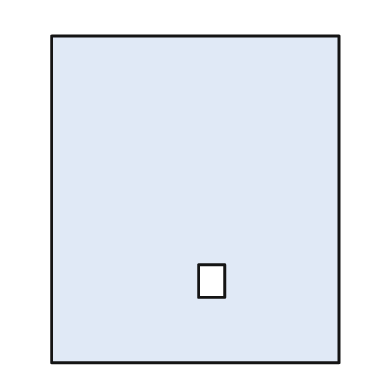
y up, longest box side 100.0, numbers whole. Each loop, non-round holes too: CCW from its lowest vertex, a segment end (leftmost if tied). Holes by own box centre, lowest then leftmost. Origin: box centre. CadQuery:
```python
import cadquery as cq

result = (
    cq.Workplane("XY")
    .moveTo(-44.0, -50.0)
    .lineTo(44.0, -50.0)
    .lineTo(44.0, 50.0)
    .lineTo(-44.0, 50.0)
    .close()
    .moveTo(1.0, -30.0)
    .lineTo(9.0, -30.0)
    .lineTo(9.0, -20.0)
    .lineTo(1.0, -20.0)
    .close()
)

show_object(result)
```